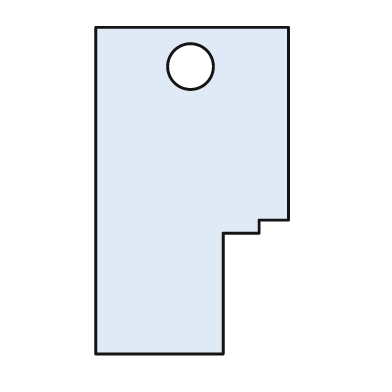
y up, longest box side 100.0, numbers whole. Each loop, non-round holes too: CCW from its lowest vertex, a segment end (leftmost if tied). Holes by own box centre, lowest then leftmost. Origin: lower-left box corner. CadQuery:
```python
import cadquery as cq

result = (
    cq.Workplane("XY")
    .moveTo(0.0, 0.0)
    .lineTo(39.0, 0.0)
    .lineTo(39.0, 37.0)
    .lineTo(50.0, 37.0)
    .lineTo(50.0, 41.0)
    .lineTo(59.0, 41.0)
    .lineTo(59.0, 100.0)
    .lineTo(0.0, 100.0)
    .close()
    .moveTo(29.0, 88.0)
    .circle(7.0)
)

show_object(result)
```